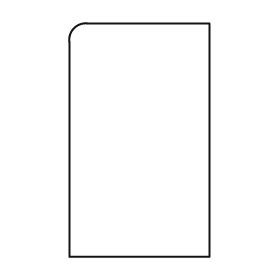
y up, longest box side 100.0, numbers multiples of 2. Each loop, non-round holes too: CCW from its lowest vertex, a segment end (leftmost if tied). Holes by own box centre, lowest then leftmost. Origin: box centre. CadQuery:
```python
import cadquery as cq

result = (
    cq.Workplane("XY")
    .moveTo(-30.0, -50.0)
    .lineTo(30.0, -50.0)
    .lineTo(30.0, 50.0)
    .lineTo(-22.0, 50.0)
    .threePointArc((-28.0, 48.0), (-30.0, 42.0))
    .close()
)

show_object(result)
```